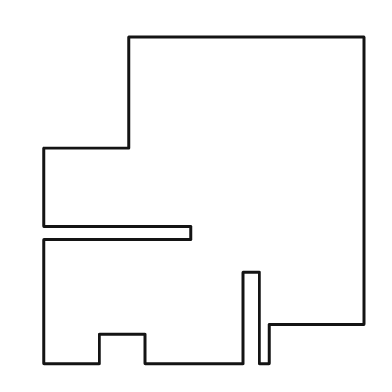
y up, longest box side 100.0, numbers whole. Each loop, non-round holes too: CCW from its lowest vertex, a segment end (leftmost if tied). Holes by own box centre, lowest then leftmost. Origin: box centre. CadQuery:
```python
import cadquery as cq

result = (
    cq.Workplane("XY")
    .moveTo(-49.0, -50.0)
    .lineTo(-32.0, -50.0)
    .lineTo(-32.0, -41.0)
    .lineTo(-18.0, -41.0)
    .lineTo(-18.0, -50.0)
    .lineTo(12.0, -50.0)
    .lineTo(12.0, -22.0)
    .lineTo(17.0, -22.0)
    .lineTo(17.0, -50.0)
    .lineTo(20.0, -50.0)
    .lineTo(20.0, -38.0)
    .lineTo(49.0, -38.0)
    .lineTo(49.0, 50.0)
    .lineTo(-23.0, 50.0)
    .lineTo(-23.0, 16.0)
    .lineTo(-49.0, 16.0)
    .lineTo(-49.0, -8.0)
    .lineTo(-4.0, -8.0)
    .lineTo(-4.0, -12.0)
    .lineTo(-49.0, -12.0)
    .close()
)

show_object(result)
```